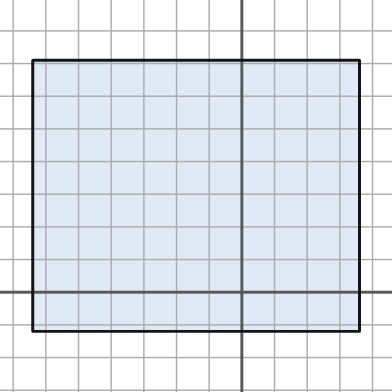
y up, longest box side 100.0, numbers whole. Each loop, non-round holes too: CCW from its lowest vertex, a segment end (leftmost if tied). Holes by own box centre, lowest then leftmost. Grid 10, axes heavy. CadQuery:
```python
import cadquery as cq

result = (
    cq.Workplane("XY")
    .moveTo(-64.0, -12.0)
    .lineTo(36.0, -12.0)
    .lineTo(36.0, 71.0)
    .lineTo(-64.0, 71.0)
    .close()
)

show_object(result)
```